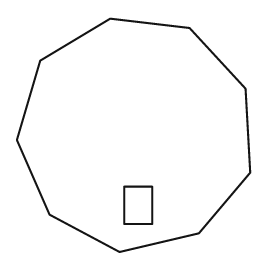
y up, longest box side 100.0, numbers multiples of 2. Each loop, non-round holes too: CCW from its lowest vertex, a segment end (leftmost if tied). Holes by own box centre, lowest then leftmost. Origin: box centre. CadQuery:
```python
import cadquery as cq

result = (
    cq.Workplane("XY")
    .moveTo(-6.0, -50.0)
    .lineTo(28.0, -42.0)
    .lineTo(50.0, -16.0)
    .lineTo(48.0, 20.0)
    .lineTo(24.0, 46.0)
    .lineTo(-10.0, 50.0)
    .lineTo(-40.0, 32.0)
    .lineTo(-50.0, -2.0)
    .lineTo(-36.0, -34.0)
    .close()
    .moveTo(-4.0, -38.0)
    .lineTo(8.0, -38.0)
    .lineTo(8.0, -22.0)
    .lineTo(-4.0, -22.0)
    .close()
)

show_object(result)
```